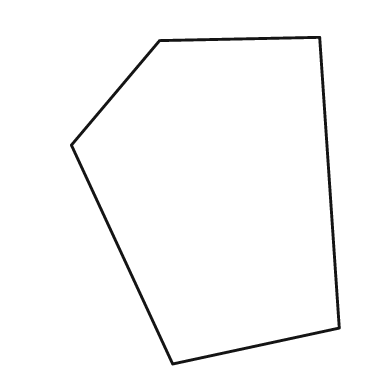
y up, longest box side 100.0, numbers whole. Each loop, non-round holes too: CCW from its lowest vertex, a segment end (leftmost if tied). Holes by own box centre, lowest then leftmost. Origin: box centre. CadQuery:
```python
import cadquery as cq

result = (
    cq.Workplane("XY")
    .moveTo(-10.0, -50.0)
    .lineTo(41.0, -39.0)
    .lineTo(35.0, 50.0)
    .lineTo(-14.0, 49.0)
    .lineTo(-41.0, 17.0)
    .close()
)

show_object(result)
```